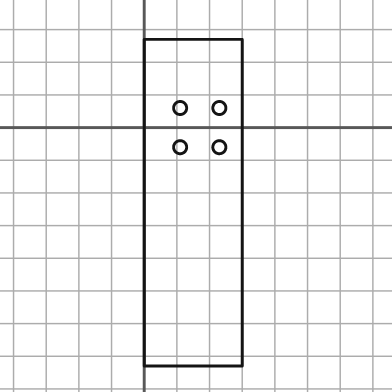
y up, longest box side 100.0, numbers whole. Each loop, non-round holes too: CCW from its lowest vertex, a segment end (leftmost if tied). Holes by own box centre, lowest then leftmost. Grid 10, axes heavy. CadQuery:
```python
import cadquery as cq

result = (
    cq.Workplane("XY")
    .moveTo(0.0, -73.0)
    .lineTo(30.0, -73.0)
    .lineTo(30.0, 27.0)
    .lineTo(0.0, 27.0)
    .close()
    .moveTo(11.0, -6.0)
    .circle(2.0)
    .moveTo(23.0, -6.0)
    .circle(2.0)
    .moveTo(11.0, 6.0)
    .circle(2.0)
    .moveTo(23.0, 6.0)
    .circle(2.0)
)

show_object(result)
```